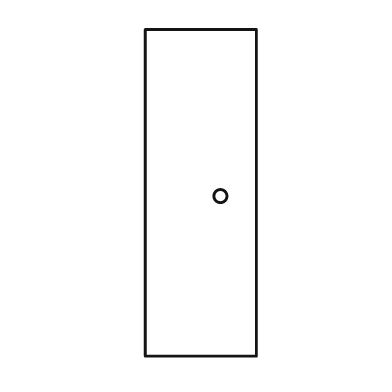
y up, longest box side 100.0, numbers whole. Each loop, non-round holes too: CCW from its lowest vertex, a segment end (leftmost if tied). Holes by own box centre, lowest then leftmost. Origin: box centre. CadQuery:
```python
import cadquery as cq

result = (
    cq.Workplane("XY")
    .moveTo(-17.0, -50.0)
    .lineTo(17.0, -50.0)
    .lineTo(17.0, 50.0)
    .lineTo(-17.0, 50.0)
    .close()
    .moveTo(6.0, -1.0)
    .circle(2.0)
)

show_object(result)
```